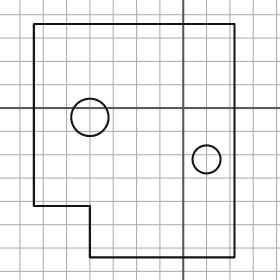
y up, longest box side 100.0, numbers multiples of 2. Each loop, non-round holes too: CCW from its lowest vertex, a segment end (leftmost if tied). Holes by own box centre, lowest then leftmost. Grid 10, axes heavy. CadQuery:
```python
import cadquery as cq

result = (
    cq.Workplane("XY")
    .moveTo(-40.0, -64.0)
    .lineTo(22.0, -64.0)
    .lineTo(22.0, 36.0)
    .lineTo(-64.0, 36.0)
    .lineTo(-64.0, -42.0)
    .lineTo(-40.0, -42.0)
    .close()
    .moveTo(10.0, -22.0)
    .circle(6.0)
    .moveTo(-40.0, -4.0)
    .circle(8.0)
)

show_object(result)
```